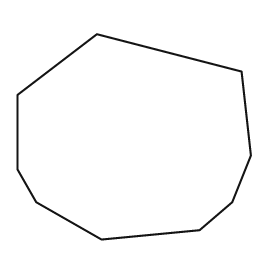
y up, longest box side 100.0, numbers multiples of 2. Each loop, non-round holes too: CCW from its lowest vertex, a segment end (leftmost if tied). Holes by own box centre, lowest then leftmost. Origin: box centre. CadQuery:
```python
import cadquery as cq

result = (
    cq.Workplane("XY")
    .moveTo(-14.0, -44.0)
    .lineTo(28.0, -40.0)
    .lineTo(42.0, -28.0)
    .lineTo(50.0, -8.0)
    .lineTo(46.0, 28.0)
    .lineTo(-16.0, 44.0)
    .lineTo(-50.0, 18.0)
    .lineTo(-50.0, -14.0)
    .lineTo(-42.0, -28.0)
    .close()
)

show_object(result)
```